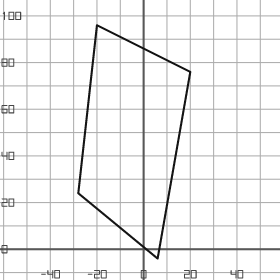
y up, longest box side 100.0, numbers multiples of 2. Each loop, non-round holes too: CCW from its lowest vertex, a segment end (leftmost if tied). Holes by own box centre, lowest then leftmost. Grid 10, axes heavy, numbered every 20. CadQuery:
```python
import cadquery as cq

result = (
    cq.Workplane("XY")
    .moveTo(6.0, -4.0)
    .lineTo(20.0, 76.0)
    .lineTo(-20.0, 96.0)
    .lineTo(-28.0, 24.0)
    .close()
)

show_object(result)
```